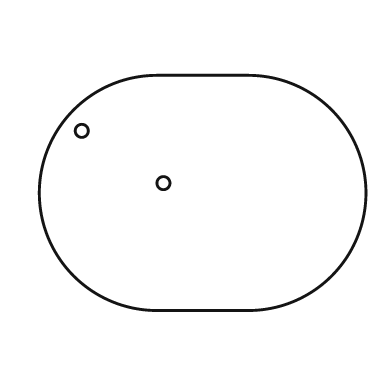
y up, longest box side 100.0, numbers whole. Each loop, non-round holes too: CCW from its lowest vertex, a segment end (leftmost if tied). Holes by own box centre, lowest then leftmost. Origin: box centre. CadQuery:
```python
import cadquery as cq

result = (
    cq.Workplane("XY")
    .moveTo(-14.0, -36.0)
    .lineTo(14.0, -36.0)
    .threePointArc((50.0, 0.0), (14.0, 36.0))
    .lineTo(-14.0, 36.0)
    .threePointArc((-50.0, 0.0), (-14.0, -36.0))
    .close()
    .moveTo(-12.0, 3.0)
    .circle(2.0)
    .moveTo(-37.0, 19.0)
    .circle(2.0)
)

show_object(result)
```